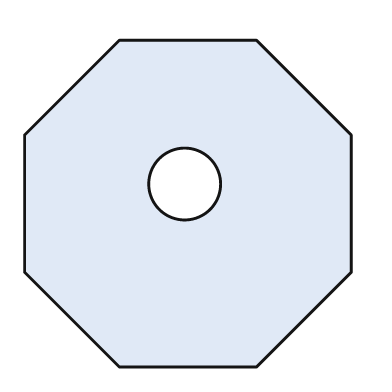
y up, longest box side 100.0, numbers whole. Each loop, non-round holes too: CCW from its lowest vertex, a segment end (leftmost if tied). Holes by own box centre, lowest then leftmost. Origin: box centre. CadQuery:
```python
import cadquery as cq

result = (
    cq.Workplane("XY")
    .moveTo(-21.0, -50.0)
    .lineTo(21.0, -50.0)
    .lineTo(50.0, -21.0)
    .lineTo(50.0, 21.0)
    .lineTo(21.0, 50.0)
    .lineTo(-21.0, 50.0)
    .lineTo(-50.0, 21.0)
    .lineTo(-50.0, -21.0)
    .close()
    .moveTo(-1.0, 6.0)
    .circle(11.0)
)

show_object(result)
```